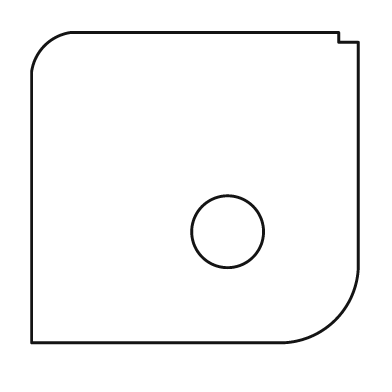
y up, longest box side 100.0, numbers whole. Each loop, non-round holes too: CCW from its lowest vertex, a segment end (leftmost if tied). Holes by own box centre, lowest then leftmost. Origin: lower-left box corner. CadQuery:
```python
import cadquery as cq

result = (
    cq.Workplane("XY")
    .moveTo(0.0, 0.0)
    .lineTo(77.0, 0.0)
    .threePointArc((93.0, 7.0), (100.0, 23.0))
    .lineTo(100.0, 92.0)
    .lineTo(94.0, 92.0)
    .lineTo(94.0, 95.0)
    .lineTo(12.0, 95.0)
    .threePointArc((4.0, 91.0), (0.0, 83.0))
    .close()
    .moveTo(60.0, 34.0)
    .circle(11.0)
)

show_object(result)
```